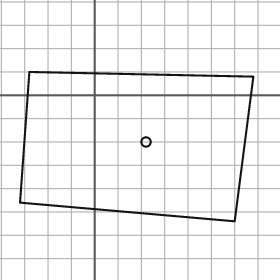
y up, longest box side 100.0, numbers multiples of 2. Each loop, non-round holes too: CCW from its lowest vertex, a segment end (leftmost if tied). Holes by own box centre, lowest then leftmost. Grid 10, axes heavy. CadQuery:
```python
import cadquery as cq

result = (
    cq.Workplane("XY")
    .moveTo(60.0, -54.0)
    .lineTo(68.0, 8.0)
    .lineTo(-28.0, 10.0)
    .lineTo(-32.0, -46.0)
    .close()
    .moveTo(22.0, -20.0)
    .circle(2.0)
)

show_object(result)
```